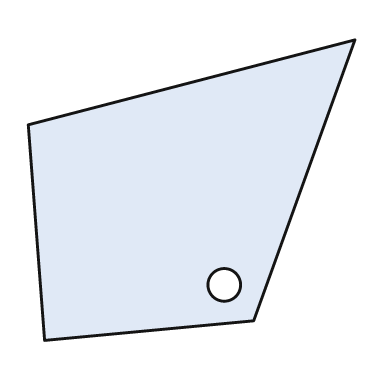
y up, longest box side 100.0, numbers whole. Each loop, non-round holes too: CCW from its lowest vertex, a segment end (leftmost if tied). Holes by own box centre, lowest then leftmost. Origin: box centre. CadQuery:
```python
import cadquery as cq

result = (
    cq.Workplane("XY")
    .moveTo(-45.0, -46.0)
    .lineTo(19.0, -40.0)
    .lineTo(50.0, 46.0)
    .lineTo(-50.0, 20.0)
    .close()
    .moveTo(10.0, -29.0)
    .circle(5.0)
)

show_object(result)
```